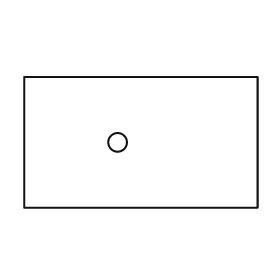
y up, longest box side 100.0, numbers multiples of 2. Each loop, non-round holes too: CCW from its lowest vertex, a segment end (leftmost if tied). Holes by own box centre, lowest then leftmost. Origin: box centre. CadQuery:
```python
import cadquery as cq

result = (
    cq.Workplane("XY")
    .moveTo(-50.0, -28.0)
    .lineTo(50.0, -28.0)
    .lineTo(50.0, 28.0)
    .lineTo(-50.0, 28.0)
    .close()
    .moveTo(-10.0, 0.0)
    .circle(4.0)
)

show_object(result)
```